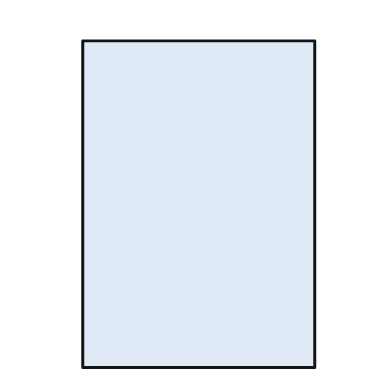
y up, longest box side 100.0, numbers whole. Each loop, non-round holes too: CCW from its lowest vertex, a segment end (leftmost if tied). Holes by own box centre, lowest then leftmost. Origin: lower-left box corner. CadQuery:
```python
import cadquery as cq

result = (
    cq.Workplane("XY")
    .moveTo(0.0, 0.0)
    .lineTo(71.0, 0.0)
    .lineTo(71.0, 100.0)
    .lineTo(0.0, 100.0)
    .close()
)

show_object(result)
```